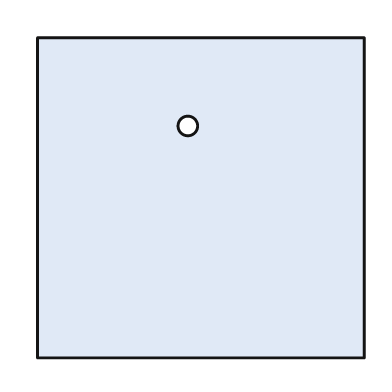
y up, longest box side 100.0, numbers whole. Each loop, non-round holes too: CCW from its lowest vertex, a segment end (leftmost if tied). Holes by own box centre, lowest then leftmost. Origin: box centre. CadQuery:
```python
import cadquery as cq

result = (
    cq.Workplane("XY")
    .moveTo(-50.0, -49.0)
    .lineTo(50.0, -49.0)
    .lineTo(50.0, 49.0)
    .lineTo(-50.0, 49.0)
    .close()
    .moveTo(-4.0, 22.0)
    .circle(3.0)
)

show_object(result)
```